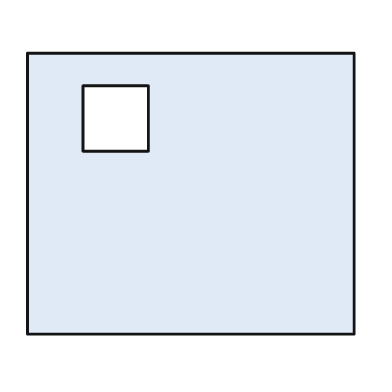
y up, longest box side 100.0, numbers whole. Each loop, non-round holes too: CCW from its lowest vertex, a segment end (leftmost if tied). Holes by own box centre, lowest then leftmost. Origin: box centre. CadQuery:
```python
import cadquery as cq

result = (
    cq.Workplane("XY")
    .moveTo(-50.0, -43.0)
    .lineTo(50.0, -43.0)
    .lineTo(50.0, 43.0)
    .lineTo(-50.0, 43.0)
    .close()
    .moveTo(-33.0, 13.0)
    .lineTo(-13.0, 13.0)
    .lineTo(-13.0, 33.0)
    .lineTo(-33.0, 33.0)
    .close()
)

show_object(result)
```